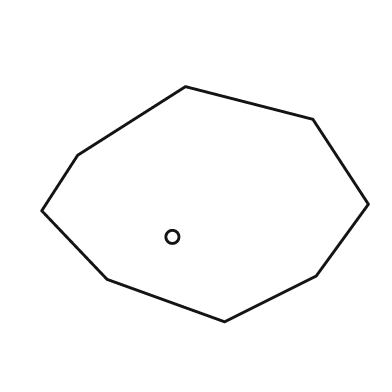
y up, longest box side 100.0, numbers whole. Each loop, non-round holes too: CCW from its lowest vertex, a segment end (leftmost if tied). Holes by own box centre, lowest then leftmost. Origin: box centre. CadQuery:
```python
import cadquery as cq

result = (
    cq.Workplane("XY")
    .moveTo(6.0, -36.0)
    .lineTo(34.0, -22.0)
    .lineTo(50.0, 0.0)
    .lineTo(33.0, 26.0)
    .lineTo(-6.0, 36.0)
    .lineTo(-39.0, 15.0)
    .lineTo(-50.0, -2.0)
    .lineTo(-30.0, -23.0)
    .close()
    .moveTo(-10.0, -10.0)
    .circle(2.0)
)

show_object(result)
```